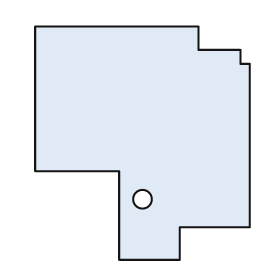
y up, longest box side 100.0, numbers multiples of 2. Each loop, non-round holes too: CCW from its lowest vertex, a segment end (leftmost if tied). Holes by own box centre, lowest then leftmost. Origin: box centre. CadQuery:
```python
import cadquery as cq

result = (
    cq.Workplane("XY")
    .moveTo(-10.0, -50.0)
    .lineTo(16.0, -50.0)
    .lineTo(16.0, -36.0)
    .lineTo(46.0, -36.0)
    .lineTo(46.0, 34.0)
    .lineTo(42.0, 34.0)
    .lineTo(42.0, 40.0)
    .lineTo(24.0, 40.0)
    .lineTo(24.0, 50.0)
    .lineTo(-46.0, 50.0)
    .lineTo(-46.0, -12.0)
    .lineTo(-10.0, -12.0)
    .close()
    .moveTo(0.0, -24.0)
    .circle(4.0)
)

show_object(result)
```